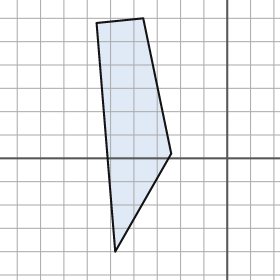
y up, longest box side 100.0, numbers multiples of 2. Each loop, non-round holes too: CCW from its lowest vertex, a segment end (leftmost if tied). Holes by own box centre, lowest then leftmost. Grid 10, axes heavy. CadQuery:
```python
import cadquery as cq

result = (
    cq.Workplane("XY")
    .moveTo(-48.0, -40.0)
    .lineTo(-24.0, 2.0)
    .lineTo(-36.0, 60.0)
    .lineTo(-56.0, 58.0)
    .close()
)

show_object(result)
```